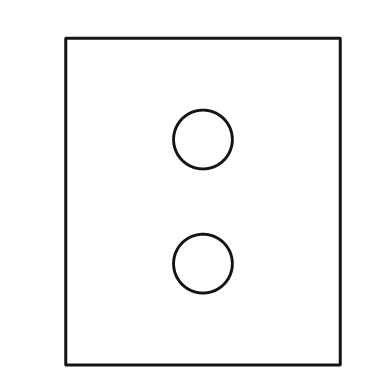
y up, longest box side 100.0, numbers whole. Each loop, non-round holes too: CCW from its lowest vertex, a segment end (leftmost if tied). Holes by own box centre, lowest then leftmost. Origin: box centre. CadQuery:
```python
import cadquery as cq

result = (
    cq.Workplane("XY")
    .moveTo(-42.0, -50.0)
    .lineTo(42.0, -50.0)
    .lineTo(42.0, 50.0)
    .lineTo(-42.0, 50.0)
    .close()
    .moveTo(0.0, -19.0)
    .circle(9.0)
    .moveTo(0.0, 19.0)
    .circle(9.0)
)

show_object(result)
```